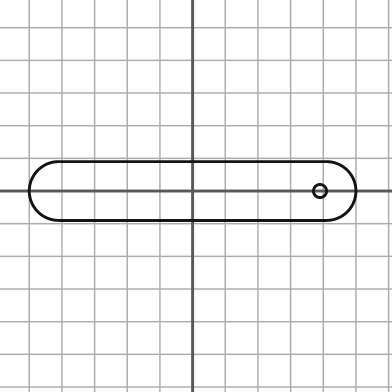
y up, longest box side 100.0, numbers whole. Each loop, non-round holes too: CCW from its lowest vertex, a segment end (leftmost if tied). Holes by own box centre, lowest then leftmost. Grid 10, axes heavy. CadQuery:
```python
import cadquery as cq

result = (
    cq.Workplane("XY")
    .moveTo(-41.0, -9.0)
    .lineTo(41.0, -9.0)
    .threePointArc((50.0, 0.0), (41.0, 9.0))
    .lineTo(-41.0, 9.0)
    .threePointArc((-50.0, 0.0), (-41.0, -9.0))
    .close()
    .moveTo(39.0, 0.0)
    .circle(2.0)
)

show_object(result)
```